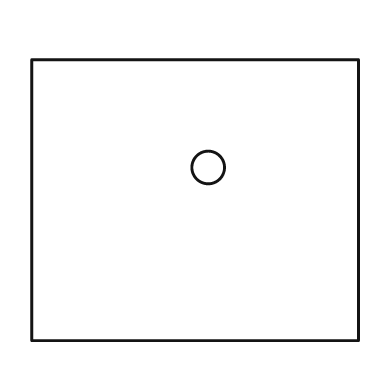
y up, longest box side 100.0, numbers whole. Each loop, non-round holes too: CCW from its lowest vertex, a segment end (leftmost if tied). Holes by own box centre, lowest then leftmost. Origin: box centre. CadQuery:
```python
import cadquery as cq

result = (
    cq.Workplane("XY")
    .moveTo(-50.0, -43.0)
    .lineTo(50.0, -43.0)
    .lineTo(50.0, 43.0)
    .lineTo(-50.0, 43.0)
    .close()
    .moveTo(4.0, 10.0)
    .circle(5.0)
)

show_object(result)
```